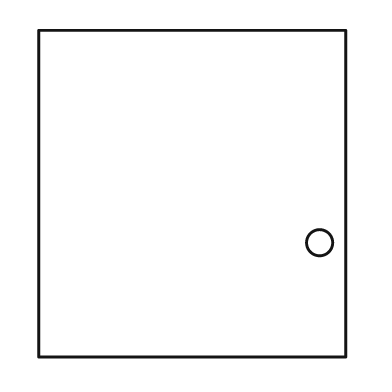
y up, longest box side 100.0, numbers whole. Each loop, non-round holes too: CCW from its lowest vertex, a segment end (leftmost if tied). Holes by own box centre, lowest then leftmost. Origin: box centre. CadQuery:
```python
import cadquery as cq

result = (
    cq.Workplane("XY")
    .moveTo(-47.0, -50.0)
    .lineTo(47.0, -50.0)
    .lineTo(47.0, 50.0)
    .lineTo(-47.0, 50.0)
    .close()
    .moveTo(39.0, -15.0)
    .circle(4.0)
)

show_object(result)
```